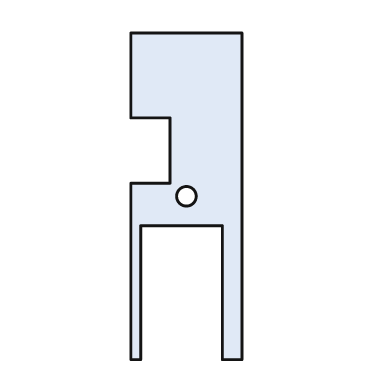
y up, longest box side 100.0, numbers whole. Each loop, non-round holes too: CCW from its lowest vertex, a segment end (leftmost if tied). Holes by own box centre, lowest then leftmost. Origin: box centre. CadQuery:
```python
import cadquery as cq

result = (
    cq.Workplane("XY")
    .moveTo(-17.0, -50.0)
    .lineTo(-14.0, -50.0)
    .lineTo(-14.0, -9.0)
    .lineTo(11.0, -9.0)
    .lineTo(11.0, -50.0)
    .lineTo(17.0, -50.0)
    .lineTo(17.0, 50.0)
    .lineTo(-17.0, 50.0)
    .lineTo(-17.0, 24.0)
    .lineTo(-5.0, 24.0)
    .lineTo(-5.0, 4.0)
    .lineTo(-17.0, 4.0)
    .close()
    .moveTo(0.0, 0.0)
    .circle(3.0)
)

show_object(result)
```